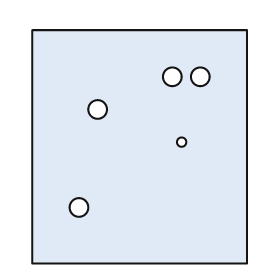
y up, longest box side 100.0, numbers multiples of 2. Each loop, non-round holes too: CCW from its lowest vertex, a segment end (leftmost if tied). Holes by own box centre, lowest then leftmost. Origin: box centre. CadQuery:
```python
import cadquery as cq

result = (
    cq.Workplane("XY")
    .moveTo(-46.0, -50.0)
    .lineTo(46.0, -50.0)
    .lineTo(46.0, 50.0)
    .lineTo(-46.0, 50.0)
    .close()
    .moveTo(-26.0, -26.0)
    .circle(4.0)
    .moveTo(18.0, 2.0)
    .circle(2.0)
    .moveTo(-18.0, 16.0)
    .circle(4.0)
    .moveTo(14.0, 30.0)
    .circle(4.0)
    .moveTo(26.0, 30.0)
    .circle(4.0)
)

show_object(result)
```